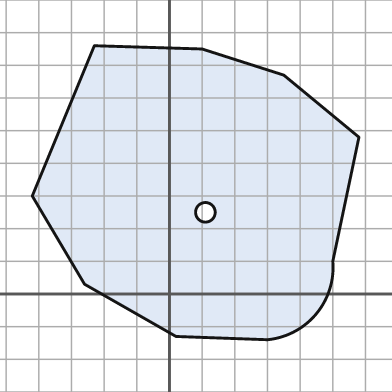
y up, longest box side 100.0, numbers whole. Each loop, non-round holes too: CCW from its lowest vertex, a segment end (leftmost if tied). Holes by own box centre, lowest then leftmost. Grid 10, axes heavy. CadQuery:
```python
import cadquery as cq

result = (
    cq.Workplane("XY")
    .moveTo(30.0, -14.0)
    .threePointArc((45.0, -6.0), (50.0, 10.0))
    .lineTo(58.0, 48.0)
    .lineTo(35.0, 67.0)
    .lineTo(10.0, 75.0)
    .lineTo(-23.0, 76.0)
    .lineTo(-42.0, 30.0)
    .lineTo(-26.0, 3.0)
    .lineTo(2.0, -13.0)
    .close()
    .moveTo(11.0, 25.0)
    .circle(3.0)
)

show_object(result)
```